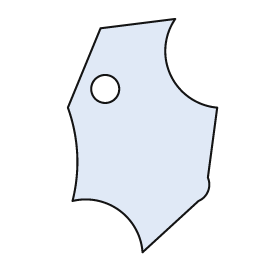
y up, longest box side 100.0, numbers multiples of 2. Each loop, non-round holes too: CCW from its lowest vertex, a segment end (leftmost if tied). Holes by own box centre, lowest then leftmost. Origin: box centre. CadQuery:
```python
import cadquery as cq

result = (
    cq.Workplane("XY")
    .moveTo(0.0, -50.0)
    .lineTo(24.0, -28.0)
    .threePointArc((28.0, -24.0), (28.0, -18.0))
    .lineTo(32.0, 12.0)
    .threePointArc((12.0, 26.0), (14.0, 50.0))
    .lineTo(-18.0, 46.0)
    .lineTo(-32.0, 12.0)
    .threePointArc((-28.0, -8.0), (-30.0, -28.0))
    .threePointArc((-10.0, -32.0), (0.0, -50.0))
    .close()
    .moveTo(-16.0, 20.0)
    .circle(6.0)
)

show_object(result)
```